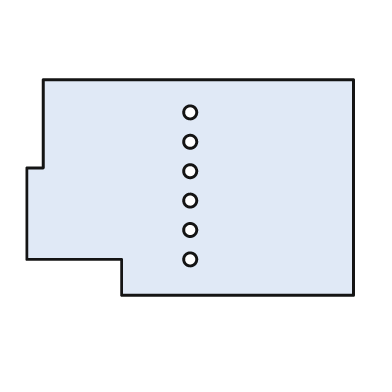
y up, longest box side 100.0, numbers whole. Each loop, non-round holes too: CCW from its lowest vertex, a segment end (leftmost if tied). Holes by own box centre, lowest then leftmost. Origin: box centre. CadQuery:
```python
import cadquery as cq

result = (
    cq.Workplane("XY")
    .moveTo(-21.0, -33.0)
    .lineTo(50.0, -33.0)
    .lineTo(50.0, 33.0)
    .lineTo(-45.0, 33.0)
    .lineTo(-45.0, 6.0)
    .lineTo(-50.0, 6.0)
    .lineTo(-50.0, -22.0)
    .lineTo(-21.0, -22.0)
    .close()
    .moveTo(0.0, -22.0)
    .circle(2.0)
    .moveTo(0.0, -13.0)
    .circle(2.0)
    .moveTo(0.0, -4.0)
    .circle(2.0)
    .moveTo(0.0, 5.0)
    .circle(2.0)
    .moveTo(0.0, 14.0)
    .circle(2.0)
    .moveTo(0.0, 23.0)
    .circle(2.0)
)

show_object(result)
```